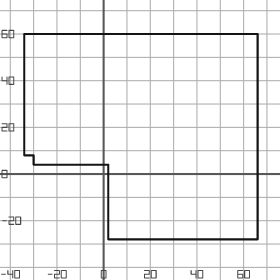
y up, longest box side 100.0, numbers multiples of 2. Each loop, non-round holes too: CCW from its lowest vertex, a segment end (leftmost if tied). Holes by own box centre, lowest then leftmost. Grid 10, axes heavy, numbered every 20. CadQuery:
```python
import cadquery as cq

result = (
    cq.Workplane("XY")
    .moveTo(2.0, -28.0)
    .lineTo(66.0, -28.0)
    .lineTo(66.0, 60.0)
    .lineTo(-34.0, 60.0)
    .lineTo(-34.0, 8.0)
    .lineTo(-30.0, 8.0)
    .lineTo(-30.0, 4.0)
    .lineTo(2.0, 4.0)
    .close()
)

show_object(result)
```